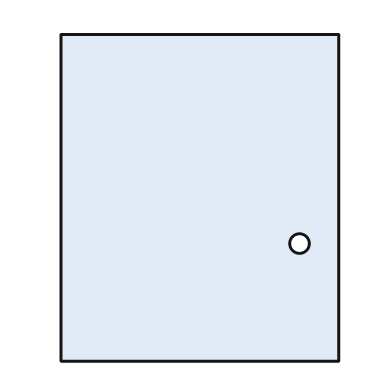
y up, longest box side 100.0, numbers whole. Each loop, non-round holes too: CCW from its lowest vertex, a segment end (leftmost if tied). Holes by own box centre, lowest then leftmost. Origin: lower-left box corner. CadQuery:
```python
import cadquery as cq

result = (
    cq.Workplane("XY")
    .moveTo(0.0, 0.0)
    .lineTo(85.0, 0.0)
    .lineTo(85.0, 100.0)
    .lineTo(0.0, 100.0)
    .close()
    .moveTo(73.0, 36.0)
    .circle(3.0)
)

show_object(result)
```